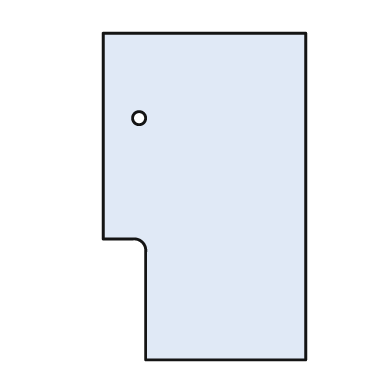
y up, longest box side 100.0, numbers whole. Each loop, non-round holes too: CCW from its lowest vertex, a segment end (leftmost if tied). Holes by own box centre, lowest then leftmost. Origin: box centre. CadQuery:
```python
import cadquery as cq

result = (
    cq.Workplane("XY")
    .moveTo(-18.0, -50.0)
    .lineTo(31.0, -50.0)
    .lineTo(31.0, 50.0)
    .lineTo(-31.0, 50.0)
    .lineTo(-31.0, -13.0)
    .lineTo(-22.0, -13.0)
    .threePointArc((-19.0, -14.0), (-18.0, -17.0))
    .close()
    .moveTo(-20.0, 24.0)
    .circle(2.0)
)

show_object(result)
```